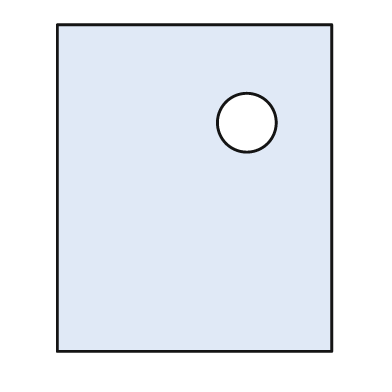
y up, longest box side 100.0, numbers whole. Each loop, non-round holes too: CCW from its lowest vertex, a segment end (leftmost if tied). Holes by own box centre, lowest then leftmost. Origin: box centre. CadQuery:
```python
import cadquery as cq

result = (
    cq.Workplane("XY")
    .moveTo(-42.0, -50.0)
    .lineTo(42.0, -50.0)
    .lineTo(42.0, 50.0)
    .lineTo(-42.0, 50.0)
    .close()
    .moveTo(16.0, 20.0)
    .circle(9.0)
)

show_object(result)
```